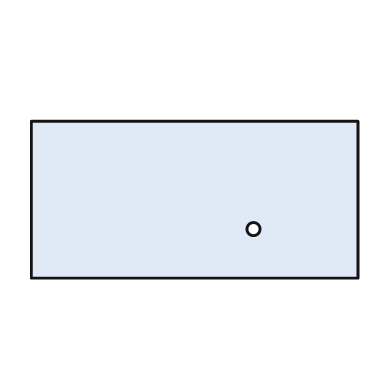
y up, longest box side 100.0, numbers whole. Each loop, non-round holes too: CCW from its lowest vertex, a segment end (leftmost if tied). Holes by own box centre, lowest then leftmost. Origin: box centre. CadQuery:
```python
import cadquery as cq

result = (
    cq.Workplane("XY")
    .moveTo(-50.0, -24.0)
    .lineTo(50.0, -24.0)
    .lineTo(50.0, 24.0)
    .lineTo(-50.0, 24.0)
    .close()
    .moveTo(18.0, -9.0)
    .circle(2.0)
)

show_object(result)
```